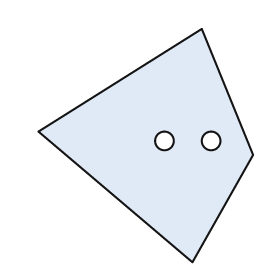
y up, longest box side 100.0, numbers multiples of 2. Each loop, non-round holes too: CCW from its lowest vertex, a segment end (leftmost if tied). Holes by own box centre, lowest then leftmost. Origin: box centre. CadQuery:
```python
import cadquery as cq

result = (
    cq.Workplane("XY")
    .moveTo(20.0, -50.0)
    .lineTo(46.0, -4.0)
    .lineTo(24.0, 50.0)
    .lineTo(-46.0, 6.0)
    .close()
    .moveTo(8.0, 2.0)
    .circle(4.0)
    .moveTo(28.0, 2.0)
    .circle(4.0)
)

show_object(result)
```